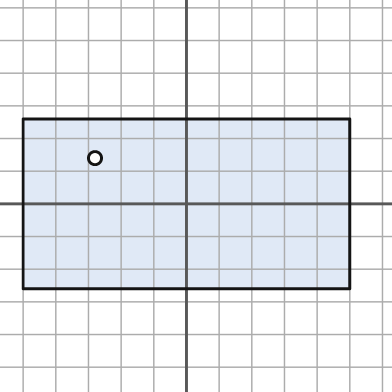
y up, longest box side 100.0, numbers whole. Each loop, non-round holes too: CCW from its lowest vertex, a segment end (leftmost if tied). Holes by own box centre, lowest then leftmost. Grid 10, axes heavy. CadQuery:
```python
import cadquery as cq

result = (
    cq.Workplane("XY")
    .moveTo(-50.0, -26.0)
    .lineTo(50.0, -26.0)
    .lineTo(50.0, 26.0)
    .lineTo(-50.0, 26.0)
    .close()
    .moveTo(-28.0, 14.0)
    .circle(2.0)
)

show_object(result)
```